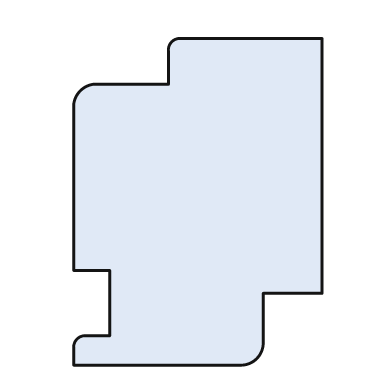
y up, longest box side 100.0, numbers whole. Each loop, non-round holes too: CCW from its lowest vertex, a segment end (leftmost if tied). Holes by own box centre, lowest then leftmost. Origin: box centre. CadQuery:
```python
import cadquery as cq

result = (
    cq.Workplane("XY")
    .moveTo(-38.0, -50.0)
    .lineTo(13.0, -50.0)
    .threePointArc((18.0, -48.0), (20.0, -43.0))
    .lineTo(20.0, -28.0)
    .lineTo(38.0, -28.0)
    .lineTo(38.0, 50.0)
    .lineTo(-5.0, 50.0)
    .threePointArc((-8.0, 49.0), (-9.0, 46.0))
    .lineTo(-9.0, 36.0)
    .lineTo(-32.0, 36.0)
    .threePointArc((-36.0, 34.0), (-38.0, 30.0))
    .lineTo(-38.0, -21.0)
    .lineTo(-27.0, -21.0)
    .lineTo(-27.0, -41.0)
    .lineTo(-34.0, -41.0)
    .threePointArc((-37.0, -42.0), (-38.0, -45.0))
    .close()
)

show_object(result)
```